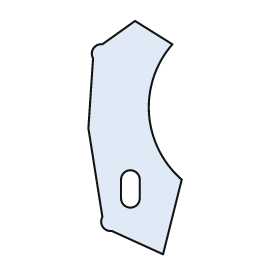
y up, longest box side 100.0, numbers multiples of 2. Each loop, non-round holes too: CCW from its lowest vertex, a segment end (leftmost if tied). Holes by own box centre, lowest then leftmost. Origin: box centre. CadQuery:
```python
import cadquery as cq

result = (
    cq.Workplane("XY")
    .moveTo(12.0, -50.0)
    .lineTo(20.0, -18.0)
    .threePointArc((6.0, 10.0), (16.0, 40.0))
    .lineTo(0.0, 50.0)
    .lineTo(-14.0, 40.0)
    .threePointArc((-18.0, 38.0), (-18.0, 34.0))
    .lineTo(-20.0, 4.0)
    .lineTo(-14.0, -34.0)
    .threePointArc((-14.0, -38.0), (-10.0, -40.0))
    .close()
    .moveTo(-6.0, -26.0)
    .threePointArc((-2.0, -30.0), (2.0, -26.0))
    .lineTo(2.0, -18.0)
    .threePointArc((-2.0, -14.0), (-6.0, -18.0))
    .close()
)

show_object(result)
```